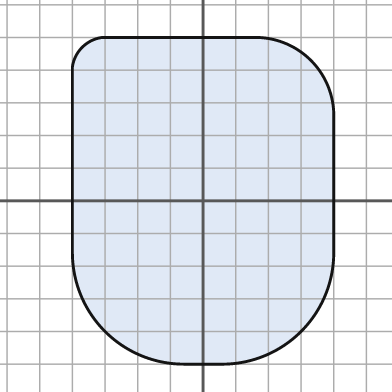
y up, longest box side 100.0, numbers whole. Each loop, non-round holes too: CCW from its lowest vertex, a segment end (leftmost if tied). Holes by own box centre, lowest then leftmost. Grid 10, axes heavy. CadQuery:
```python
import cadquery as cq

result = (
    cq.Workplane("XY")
    .moveTo(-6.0, -50.0)
    .lineTo(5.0, -50.0)
    .threePointArc((30.0, -40.0), (40.0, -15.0))
    .lineTo(40.0, 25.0)
    .threePointArc((33.0, 43.0), (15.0, 50.0))
    .lineTo(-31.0, 50.0)
    .threePointArc((-37.0, 47.0), (-40.0, 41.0))
    .lineTo(-40.0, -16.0)
    .threePointArc((-30.0, -40.0), (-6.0, -50.0))
    .close()
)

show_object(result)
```